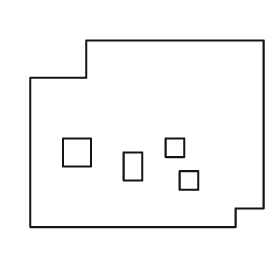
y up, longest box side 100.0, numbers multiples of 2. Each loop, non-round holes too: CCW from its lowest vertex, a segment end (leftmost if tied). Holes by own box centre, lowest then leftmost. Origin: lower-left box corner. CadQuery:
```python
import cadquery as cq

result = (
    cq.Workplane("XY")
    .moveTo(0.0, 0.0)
    .lineTo(88.0, 0.0)
    .lineTo(88.0, 8.0)
    .lineTo(100.0, 8.0)
    .lineTo(100.0, 80.0)
    .lineTo(24.0, 80.0)
    .lineTo(24.0, 64.0)
    .lineTo(0.0, 64.0)
    .close()
    .moveTo(64.0, 16.0)
    .lineTo(72.0, 16.0)
    .lineTo(72.0, 24.0)
    .lineTo(64.0, 24.0)
    .close()
    .moveTo(40.0, 20.0)
    .lineTo(48.0, 20.0)
    .lineTo(48.0, 32.0)
    .lineTo(40.0, 32.0)
    .close()
    .moveTo(14.0, 26.0)
    .lineTo(26.0, 26.0)
    .lineTo(26.0, 38.0)
    .lineTo(14.0, 38.0)
    .close()
    .moveTo(58.0, 30.0)
    .lineTo(66.0, 30.0)
    .lineTo(66.0, 38.0)
    .lineTo(58.0, 38.0)
    .close()
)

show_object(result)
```